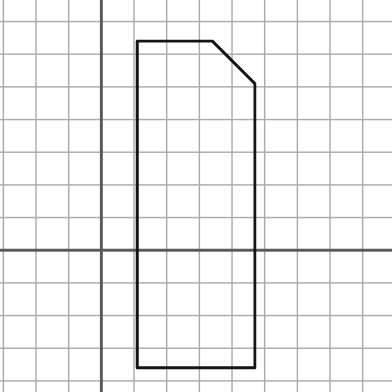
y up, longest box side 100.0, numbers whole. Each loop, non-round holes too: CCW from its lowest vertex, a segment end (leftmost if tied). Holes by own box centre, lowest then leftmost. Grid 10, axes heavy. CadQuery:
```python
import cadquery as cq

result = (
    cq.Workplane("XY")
    .moveTo(11.0, -36.0)
    .lineTo(47.0, -36.0)
    .lineTo(47.0, 51.0)
    .lineTo(34.0, 64.0)
    .lineTo(11.0, 64.0)
    .close()
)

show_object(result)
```